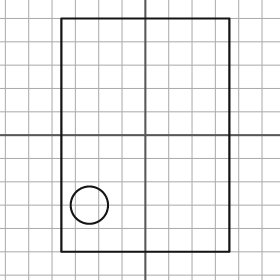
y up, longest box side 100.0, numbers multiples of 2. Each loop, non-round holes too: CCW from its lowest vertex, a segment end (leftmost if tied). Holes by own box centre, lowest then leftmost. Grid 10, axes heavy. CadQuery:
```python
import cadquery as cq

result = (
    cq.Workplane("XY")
    .moveTo(-36.0, -50.0)
    .lineTo(36.0, -50.0)
    .lineTo(36.0, 50.0)
    .lineTo(-36.0, 50.0)
    .close()
    .moveTo(-24.0, -30.0)
    .circle(8.0)
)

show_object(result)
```